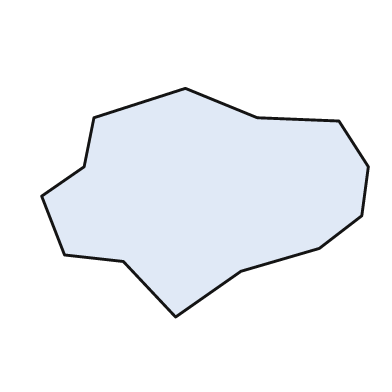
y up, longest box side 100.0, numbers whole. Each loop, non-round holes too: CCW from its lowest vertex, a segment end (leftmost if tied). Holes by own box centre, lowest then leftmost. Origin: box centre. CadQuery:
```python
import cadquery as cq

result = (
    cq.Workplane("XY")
    .moveTo(-9.0, -35.0)
    .lineTo(11.0, -21.0)
    .lineTo(35.0, -14.0)
    .lineTo(48.0, -4.0)
    .lineTo(50.0, 11.0)
    .lineTo(41.0, 25.0)
    .lineTo(16.0, 26.0)
    .lineTo(-6.0, 35.0)
    .lineTo(-34.0, 26.0)
    .lineTo(-37.0, 11.0)
    .lineTo(-50.0, 2.0)
    .lineTo(-43.0, -16.0)
    .lineTo(-25.0, -18.0)
    .close()
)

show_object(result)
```